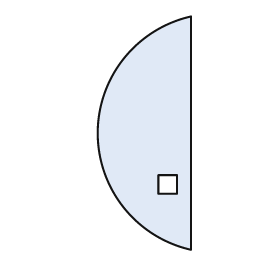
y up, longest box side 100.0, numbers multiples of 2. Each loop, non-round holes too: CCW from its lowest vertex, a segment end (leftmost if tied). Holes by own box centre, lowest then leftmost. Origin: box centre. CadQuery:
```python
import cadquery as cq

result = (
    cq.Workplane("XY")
    .moveTo(20.0, -50.0)
    .lineTo(20.0, 50.0)
    .threePointArc((-20.0, 0.0), (20.0, -50.0))
    .close()
    .moveTo(6.0, -26.0)
    .lineTo(14.0, -26.0)
    .lineTo(14.0, -18.0)
    .lineTo(6.0, -18.0)
    .close()
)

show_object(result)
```